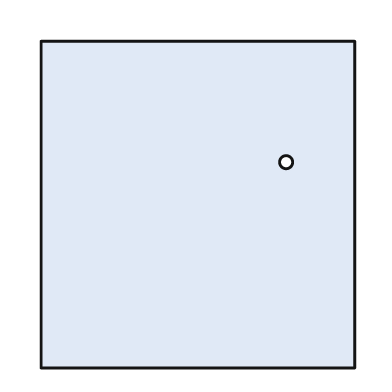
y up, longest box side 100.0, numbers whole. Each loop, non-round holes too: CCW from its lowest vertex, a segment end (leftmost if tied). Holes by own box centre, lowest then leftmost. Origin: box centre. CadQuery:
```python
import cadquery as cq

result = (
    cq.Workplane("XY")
    .moveTo(-48.0, -50.0)
    .lineTo(48.0, -50.0)
    .lineTo(48.0, 50.0)
    .lineTo(-48.0, 50.0)
    .close()
    .moveTo(27.0, 13.0)
    .circle(2.0)
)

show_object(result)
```